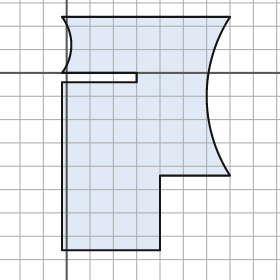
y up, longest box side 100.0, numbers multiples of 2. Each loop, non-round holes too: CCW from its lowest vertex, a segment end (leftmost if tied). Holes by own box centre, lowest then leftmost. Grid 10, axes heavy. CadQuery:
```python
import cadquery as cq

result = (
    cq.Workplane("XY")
    .moveTo(-2.0, -76.0)
    .lineTo(40.0, -76.0)
    .lineTo(40.0, -44.0)
    .lineTo(70.0, -44.0)
    .threePointArc((60.0, -10.0), (70.0, 24.0))
    .lineTo(-2.0, 24.0)
    .threePointArc((2.0, 12.0), (-2.0, 0.0))
    .lineTo(30.0, 0.0)
    .lineTo(30.0, -4.0)
    .lineTo(-2.0, -4.0)
    .close()
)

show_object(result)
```